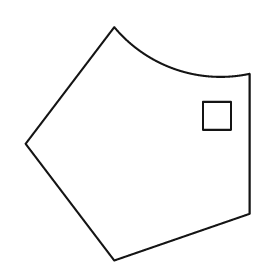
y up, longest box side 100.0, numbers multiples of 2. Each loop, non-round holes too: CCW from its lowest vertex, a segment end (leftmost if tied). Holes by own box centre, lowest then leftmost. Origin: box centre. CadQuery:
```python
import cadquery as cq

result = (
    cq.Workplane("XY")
    .moveTo(-10.0, -50.0)
    .lineTo(48.0, -30.0)
    .lineTo(48.0, 30.0)
    .threePointArc((16.0, 32.0), (-10.0, 50.0))
    .lineTo(-48.0, 0.0)
    .close()
    .moveTo(28.0, 6.0)
    .lineTo(40.0, 6.0)
    .lineTo(40.0, 18.0)
    .lineTo(28.0, 18.0)
    .close()
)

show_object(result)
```